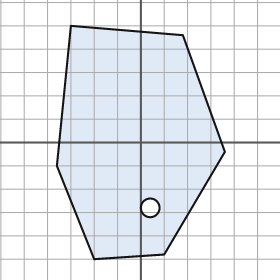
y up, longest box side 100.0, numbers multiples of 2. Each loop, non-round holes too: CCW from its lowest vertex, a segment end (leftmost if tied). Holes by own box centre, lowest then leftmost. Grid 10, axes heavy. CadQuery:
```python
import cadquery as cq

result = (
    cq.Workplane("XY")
    .moveTo(-20.0, -50.0)
    .lineTo(10.0, -48.0)
    .lineTo(36.0, -4.0)
    .lineTo(18.0, 46.0)
    .lineTo(-30.0, 50.0)
    .lineTo(-36.0, -10.0)
    .close()
    .moveTo(4.0, -28.0)
    .circle(4.0)
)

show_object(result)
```